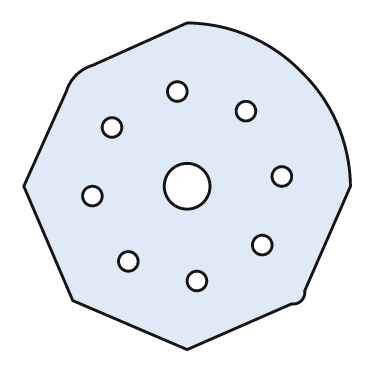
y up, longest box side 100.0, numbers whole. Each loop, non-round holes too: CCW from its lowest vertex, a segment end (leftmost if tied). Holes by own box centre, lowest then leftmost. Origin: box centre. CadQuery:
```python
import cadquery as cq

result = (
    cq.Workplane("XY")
    .moveTo(0.0, -50.0)
    .lineTo(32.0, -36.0)
    .threePointArc((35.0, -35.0), (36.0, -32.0))
    .lineTo(50.0, 0.0)
    .threePointArc((46.0, 19.0), (35.0, 35.0))
    .threePointArc((19.0, 46.0), (0.0, 50.0))
    .lineTo(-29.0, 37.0)
    .threePointArc((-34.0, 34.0), (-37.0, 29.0))
    .lineTo(-50.0, 0.0)
    .lineTo(-35.0, -35.0)
    .close()
    .moveTo(3.0, -29.0)
    .circle(3.0)
    .moveTo(-18.0, -23.0)
    .circle(3.0)
    .moveTo(23.0, -18.0)
    .circle(3.0)
    .moveTo(-29.0, -3.0)
    .circle(3.0)
    .moveTo(0.0, 0.0)
    .circle(7.0)
    .moveTo(29.0, 3.0)
    .circle(3.0)
    .moveTo(-23.0, 18.0)
    .circle(3.0)
    .moveTo(18.0, 23.0)
    .circle(3.0)
    .moveTo(-3.0, 29.0)
    .circle(3.0)
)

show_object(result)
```